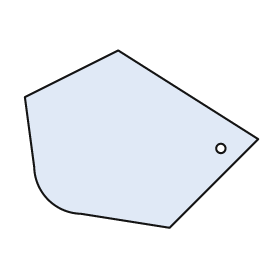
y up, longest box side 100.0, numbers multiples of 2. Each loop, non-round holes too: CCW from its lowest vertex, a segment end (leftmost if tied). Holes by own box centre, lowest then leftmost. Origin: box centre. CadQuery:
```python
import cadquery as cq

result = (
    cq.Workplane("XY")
    .moveTo(12.0, -38.0)
    .lineTo(50.0, 0.0)
    .lineTo(-10.0, 38.0)
    .lineTo(-50.0, 18.0)
    .lineTo(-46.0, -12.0)
    .threePointArc((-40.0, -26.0), (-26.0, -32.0))
    .close()
    .moveTo(34.0, -4.0)
    .circle(2.0)
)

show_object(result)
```